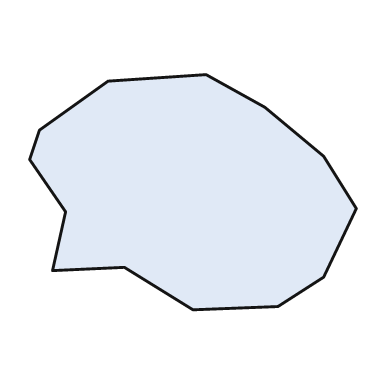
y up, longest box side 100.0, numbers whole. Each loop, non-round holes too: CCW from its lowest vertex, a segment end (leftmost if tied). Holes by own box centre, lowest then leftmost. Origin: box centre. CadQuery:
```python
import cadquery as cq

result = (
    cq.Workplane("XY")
    .moveTo(0.0, -36.0)
    .lineTo(26.0, -35.0)
    .lineTo(40.0, -26.0)
    .lineTo(50.0, -5.0)
    .lineTo(40.0, 11.0)
    .lineTo(22.0, 26.0)
    .lineTo(4.0, 36.0)
    .lineTo(-26.0, 34.0)
    .lineTo(-47.0, 19.0)
    .lineTo(-50.0, 10.0)
    .lineTo(-39.0, -6.0)
    .lineTo(-43.0, -24.0)
    .lineTo(-21.0, -23.0)
    .close()
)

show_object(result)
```